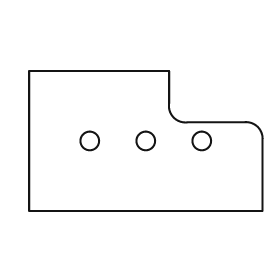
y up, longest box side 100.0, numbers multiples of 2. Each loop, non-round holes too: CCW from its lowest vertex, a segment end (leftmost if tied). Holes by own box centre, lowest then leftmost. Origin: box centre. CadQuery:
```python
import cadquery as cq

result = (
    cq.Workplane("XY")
    .moveTo(-50.0, -30.0)
    .lineTo(50.0, -30.0)
    .lineTo(50.0, 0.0)
    .threePointArc((48.0, 6.0), (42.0, 8.0))
    .lineTo(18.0, 8.0)
    .threePointArc((12.0, 10.0), (10.0, 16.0))
    .lineTo(10.0, 30.0)
    .lineTo(-50.0, 30.0)
    .close()
    .moveTo(-24.0, 0.0)
    .circle(4.0)
    .moveTo(0.0, 0.0)
    .circle(4.0)
    .moveTo(24.0, 0.0)
    .circle(4.0)
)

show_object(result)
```